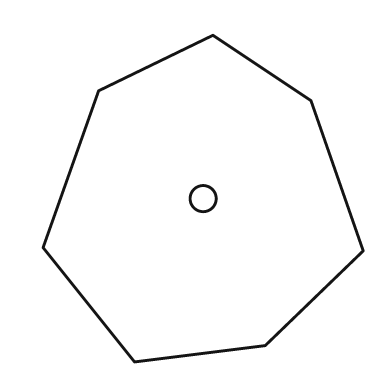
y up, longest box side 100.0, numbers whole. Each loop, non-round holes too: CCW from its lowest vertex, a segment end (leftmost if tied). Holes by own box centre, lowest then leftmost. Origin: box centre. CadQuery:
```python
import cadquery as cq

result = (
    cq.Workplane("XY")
    .moveTo(-21.0, -50.0)
    .lineTo(19.0, -45.0)
    .lineTo(49.0, -16.0)
    .lineTo(33.0, 30.0)
    .lineTo(3.0, 50.0)
    .lineTo(-32.0, 33.0)
    .lineTo(-49.0, -15.0)
    .close()
    .moveTo(0.0, 0.0)
    .circle(4.0)
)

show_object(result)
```